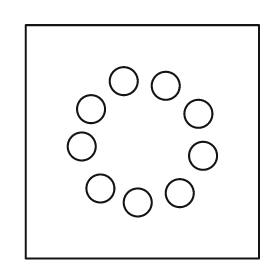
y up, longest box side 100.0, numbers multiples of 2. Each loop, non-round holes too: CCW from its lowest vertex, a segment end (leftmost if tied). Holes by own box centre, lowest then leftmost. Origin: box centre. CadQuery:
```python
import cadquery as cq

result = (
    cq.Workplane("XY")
    .moveTo(-50.0, -50.0)
    .lineTo(50.0, -50.0)
    .lineTo(50.0, 50.0)
    .lineTo(-50.0, 50.0)
    .close()
    .moveTo(-2.0, -26.0)
    .circle(6.0)
    .moveTo(16.0, -22.0)
    .circle(6.0)
    .moveTo(-18.0, -20.0)
    .circle(6.0)
    .moveTo(26.0, -6.0)
    .circle(6.0)
    .moveTo(-26.0, -2.0)
    .circle(6.0)
    .moveTo(24.0, 12.0)
    .circle(6.0)
    .moveTo(-22.0, 14.0)
    .circle(6.0)
    .moveTo(10.0, 24.0)
    .circle(6.0)
    .moveTo(-8.0, 26.0)
    .circle(6.0)
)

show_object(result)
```